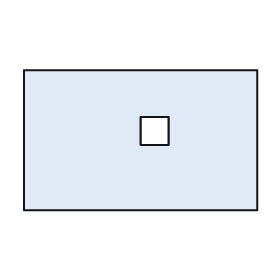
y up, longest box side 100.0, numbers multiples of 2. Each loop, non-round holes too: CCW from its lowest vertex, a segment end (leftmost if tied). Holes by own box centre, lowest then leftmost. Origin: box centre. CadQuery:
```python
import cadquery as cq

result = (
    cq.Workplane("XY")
    .moveTo(-50.0, -30.0)
    .lineTo(50.0, -30.0)
    .lineTo(50.0, 30.0)
    .lineTo(-50.0, 30.0)
    .close()
    .moveTo(0.0, -2.0)
    .lineTo(12.0, -2.0)
    .lineTo(12.0, 10.0)
    .lineTo(0.0, 10.0)
    .close()
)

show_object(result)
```